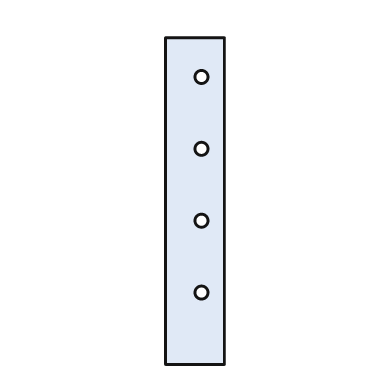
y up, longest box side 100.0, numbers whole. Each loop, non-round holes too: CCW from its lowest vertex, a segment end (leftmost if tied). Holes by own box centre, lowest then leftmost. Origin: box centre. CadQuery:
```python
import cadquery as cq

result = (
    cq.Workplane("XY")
    .moveTo(-9.0, -50.0)
    .lineTo(9.0, -50.0)
    .lineTo(9.0, 50.0)
    .lineTo(-9.0, 50.0)
    .close()
    .moveTo(2.0, -28.0)
    .circle(2.0)
    .moveTo(2.0, -6.0)
    .circle(2.0)
    .moveTo(2.0, 16.0)
    .circle(2.0)
    .moveTo(2.0, 38.0)
    .circle(2.0)
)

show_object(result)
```